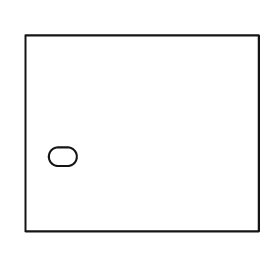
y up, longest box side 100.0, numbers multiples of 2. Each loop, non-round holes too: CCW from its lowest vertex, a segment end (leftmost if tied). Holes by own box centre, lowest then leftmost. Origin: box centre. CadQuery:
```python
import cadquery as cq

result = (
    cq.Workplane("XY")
    .moveTo(-50.0, -42.0)
    .lineTo(50.0, -42.0)
    .lineTo(50.0, 42.0)
    .lineTo(-50.0, 42.0)
    .close()
    .moveTo(-36.0, -14.0)
    .lineTo(-32.0, -14.0)
    .threePointArc((-28.0, -10.0), (-32.0, -6.0))
    .lineTo(-36.0, -6.0)
    .threePointArc((-40.0, -10.0), (-36.0, -14.0))
    .close()
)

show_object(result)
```